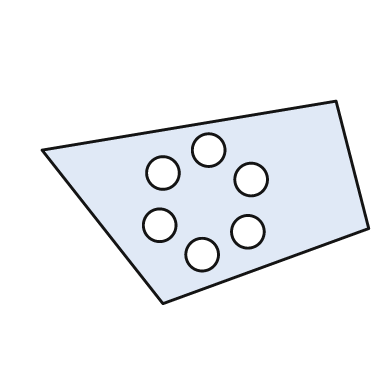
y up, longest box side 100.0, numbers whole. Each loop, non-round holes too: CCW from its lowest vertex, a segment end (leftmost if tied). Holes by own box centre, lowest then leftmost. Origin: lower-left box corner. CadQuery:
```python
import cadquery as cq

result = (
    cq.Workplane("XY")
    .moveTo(37.0, 0.0)
    .lineTo(100.0, 23.0)
    .lineTo(90.0, 62.0)
    .lineTo(0.0, 47.0)
    .close()
    .moveTo(49.0, 15.0)
    .circle(5.0)
    .moveTo(63.0, 22.0)
    .circle(5.0)
    .moveTo(36.0, 24.0)
    .circle(5.0)
    .moveTo(64.0, 38.0)
    .circle(5.0)
    .moveTo(37.0, 40.0)
    .circle(5.0)
    .moveTo(51.0, 47.0)
    .circle(5.0)
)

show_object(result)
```